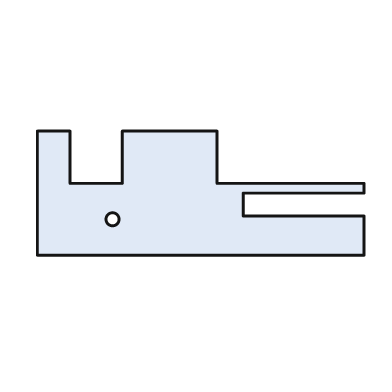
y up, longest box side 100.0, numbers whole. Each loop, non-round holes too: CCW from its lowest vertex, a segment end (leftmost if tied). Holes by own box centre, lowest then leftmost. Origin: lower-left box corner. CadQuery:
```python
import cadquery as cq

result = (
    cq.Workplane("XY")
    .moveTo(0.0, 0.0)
    .lineTo(100.0, 0.0)
    .lineTo(100.0, 12.0)
    .lineTo(63.0, 12.0)
    .lineTo(63.0, 19.0)
    .lineTo(100.0, 19.0)
    .lineTo(100.0, 22.0)
    .lineTo(55.0, 22.0)
    .lineTo(55.0, 38.0)
    .lineTo(26.0, 38.0)
    .lineTo(26.0, 22.0)
    .lineTo(10.0, 22.0)
    .lineTo(10.0, 38.0)
    .lineTo(0.0, 38.0)
    .close()
    .moveTo(23.0, 11.0)
    .circle(2.0)
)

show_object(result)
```